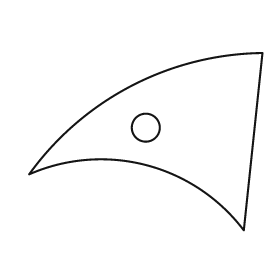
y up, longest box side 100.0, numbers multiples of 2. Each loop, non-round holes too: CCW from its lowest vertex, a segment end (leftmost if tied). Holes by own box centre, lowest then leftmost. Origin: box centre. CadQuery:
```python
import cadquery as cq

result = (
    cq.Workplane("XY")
    .moveTo(42.0, -38.0)
    .lineTo(50.0, 38.0)
    .threePointArc((-6.0, 24.0), (-50.0, -14.0))
    .threePointArc((0.0, -10.0), (42.0, -38.0))
    .close()
    .moveTo(0.0, 6.0)
    .circle(6.0)
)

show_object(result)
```